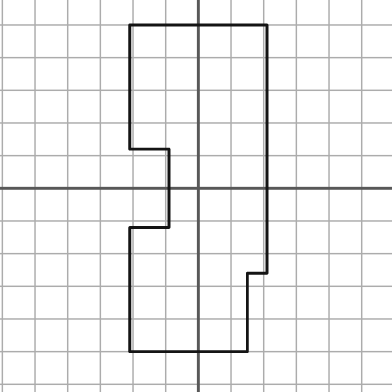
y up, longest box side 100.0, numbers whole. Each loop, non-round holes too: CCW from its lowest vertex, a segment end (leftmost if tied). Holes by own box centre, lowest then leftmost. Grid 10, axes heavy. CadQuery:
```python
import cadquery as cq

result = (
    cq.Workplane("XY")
    .moveTo(-21.0, -50.0)
    .lineTo(15.0, -50.0)
    .lineTo(15.0, -26.0)
    .lineTo(21.0, -26.0)
    .lineTo(21.0, 50.0)
    .lineTo(-21.0, 50.0)
    .lineTo(-21.0, 12.0)
    .lineTo(-9.0, 12.0)
    .lineTo(-9.0, -12.0)
    .lineTo(-21.0, -12.0)
    .close()
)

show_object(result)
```